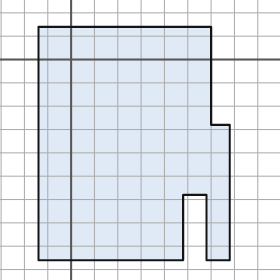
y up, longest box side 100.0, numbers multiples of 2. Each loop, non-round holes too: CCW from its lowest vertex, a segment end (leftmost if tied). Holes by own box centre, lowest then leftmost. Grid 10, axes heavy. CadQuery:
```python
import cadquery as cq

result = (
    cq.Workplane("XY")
    .moveTo(-14.0, -86.0)
    .lineTo(48.0, -86.0)
    .lineTo(48.0, -58.0)
    .lineTo(58.0, -58.0)
    .lineTo(58.0, -86.0)
    .lineTo(68.0, -86.0)
    .lineTo(68.0, -28.0)
    .lineTo(60.0, -28.0)
    .lineTo(60.0, 14.0)
    .lineTo(-14.0, 14.0)
    .close()
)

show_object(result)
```